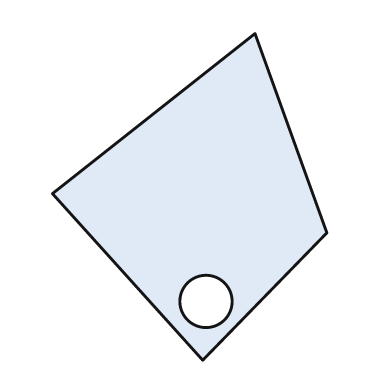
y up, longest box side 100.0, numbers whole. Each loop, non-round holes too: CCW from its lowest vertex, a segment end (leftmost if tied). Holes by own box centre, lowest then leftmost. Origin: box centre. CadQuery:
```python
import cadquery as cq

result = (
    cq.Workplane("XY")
    .moveTo(4.0, -50.0)
    .lineTo(42.0, -11.0)
    .lineTo(20.0, 50.0)
    .lineTo(-42.0, 1.0)
    .close()
    .moveTo(5.0, -32.0)
    .circle(8.0)
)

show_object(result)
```